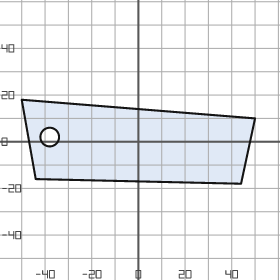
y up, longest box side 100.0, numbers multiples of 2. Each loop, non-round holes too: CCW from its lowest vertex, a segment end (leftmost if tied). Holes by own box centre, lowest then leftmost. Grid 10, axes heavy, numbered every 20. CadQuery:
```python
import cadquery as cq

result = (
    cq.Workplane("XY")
    .moveTo(44.0, -18.0)
    .lineTo(50.0, 10.0)
    .lineTo(-50.0, 18.0)
    .lineTo(-44.0, -16.0)
    .close()
    .moveTo(-38.0, 2.0)
    .circle(4.0)
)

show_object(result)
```